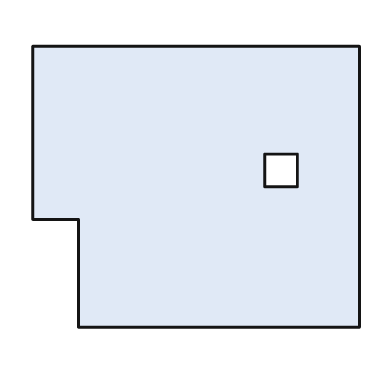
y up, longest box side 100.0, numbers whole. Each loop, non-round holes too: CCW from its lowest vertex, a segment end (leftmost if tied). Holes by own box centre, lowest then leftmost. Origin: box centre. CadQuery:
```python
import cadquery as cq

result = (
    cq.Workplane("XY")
    .moveTo(-36.0, -43.0)
    .lineTo(50.0, -43.0)
    .lineTo(50.0, 43.0)
    .lineTo(-50.0, 43.0)
    .lineTo(-50.0, -10.0)
    .lineTo(-36.0, -10.0)
    .close()
    .moveTo(21.0, 0.0)
    .lineTo(31.0, 0.0)
    .lineTo(31.0, 10.0)
    .lineTo(21.0, 10.0)
    .close()
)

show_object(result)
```